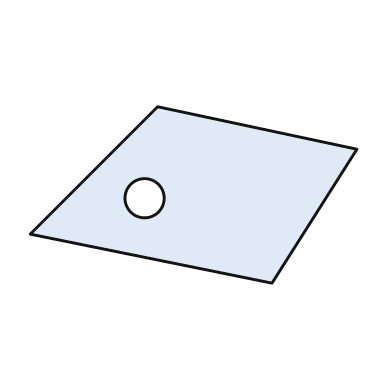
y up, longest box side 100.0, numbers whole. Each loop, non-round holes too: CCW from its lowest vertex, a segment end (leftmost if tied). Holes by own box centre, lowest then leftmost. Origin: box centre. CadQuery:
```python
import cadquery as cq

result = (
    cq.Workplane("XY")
    .moveTo(24.0, -27.0)
    .lineTo(50.0, 14.0)
    .lineTo(-11.0, 27.0)
    .lineTo(-50.0, -12.0)
    .close()
    .moveTo(-15.0, -1.0)
    .circle(6.0)
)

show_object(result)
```